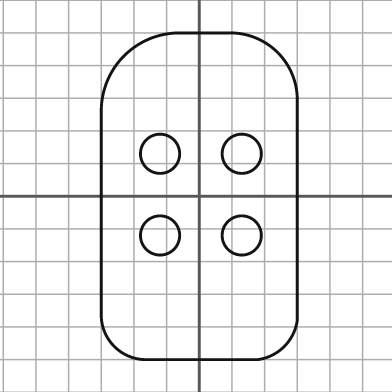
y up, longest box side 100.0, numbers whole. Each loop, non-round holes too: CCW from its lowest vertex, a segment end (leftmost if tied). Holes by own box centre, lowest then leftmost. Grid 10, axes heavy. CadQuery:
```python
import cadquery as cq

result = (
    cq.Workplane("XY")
    .moveTo(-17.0, -50.0)
    .lineTo(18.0, -50.0)
    .threePointArc((26.0, -46.0), (30.0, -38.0))
    .lineTo(30.0, 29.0)
    .threePointArc((24.0, 44.0), (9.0, 50.0))
    .lineTo(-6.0, 50.0)
    .threePointArc((-23.0, 43.0), (-30.0, 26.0))
    .lineTo(-30.0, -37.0)
    .threePointArc((-26.0, -46.0), (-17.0, -50.0))
    .close()
    .moveTo(-12.0, -12.0)
    .circle(6.0)
    .moveTo(13.0, -12.0)
    .circle(6.0)
    .moveTo(-12.0, 13.0)
    .circle(6.0)
    .moveTo(13.0, 13.0)
    .circle(6.0)
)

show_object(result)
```